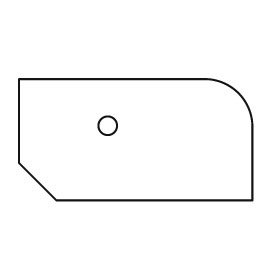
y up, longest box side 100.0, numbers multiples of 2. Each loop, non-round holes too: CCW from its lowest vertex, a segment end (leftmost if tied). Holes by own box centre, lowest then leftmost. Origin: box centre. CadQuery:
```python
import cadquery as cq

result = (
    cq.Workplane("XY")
    .moveTo(-34.0, -26.0)
    .lineTo(50.0, -26.0)
    .lineTo(50.0, 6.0)
    .threePointArc((44.0, 20.0), (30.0, 26.0))
    .lineTo(-50.0, 26.0)
    .lineTo(-50.0, -10.0)
    .close()
    .moveTo(-12.0, 6.0)
    .circle(4.0)
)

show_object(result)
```